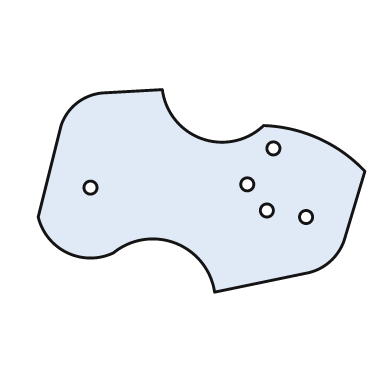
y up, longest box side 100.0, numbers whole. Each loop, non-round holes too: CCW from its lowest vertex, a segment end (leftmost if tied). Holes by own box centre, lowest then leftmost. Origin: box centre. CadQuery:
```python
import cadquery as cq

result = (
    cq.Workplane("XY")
    .moveTo(4.0, -31.0)
    .lineTo(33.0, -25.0)
    .threePointArc((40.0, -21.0), (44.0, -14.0))
    .lineTo(50.0, 6.0)
    .threePointArc((36.0, 16.0), (19.0, 20.0))
    .threePointArc((0.0, 16.0), (-12.0, 31.0))
    .lineTo(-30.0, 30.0)
    .threePointArc((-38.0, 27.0), (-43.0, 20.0))
    .lineTo(-50.0, -8.0)
    .threePointArc((-41.0, -19.0), (-27.0, -19.0))
    .threePointArc((-8.0, -16.0), (4.0, -31.0))
    .close()
    .moveTo(32.0, -8.0)
    .circle(2.0)
    .moveTo(20.0, -6.0)
    .circle(2.0)
    .moveTo(-34.0, 1.0)
    .circle(2.0)
    .moveTo(14.0, 2.0)
    .circle(2.0)
    .moveTo(22.0, 13.0)
    .circle(2.0)
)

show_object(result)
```